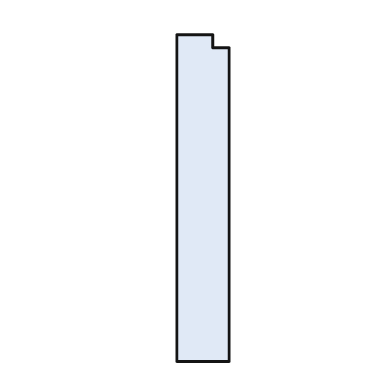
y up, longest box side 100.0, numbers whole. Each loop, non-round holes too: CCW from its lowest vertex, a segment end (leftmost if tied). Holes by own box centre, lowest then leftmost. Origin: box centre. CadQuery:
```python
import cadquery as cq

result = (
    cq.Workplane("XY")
    .moveTo(-8.0, -50.0)
    .lineTo(8.0, -50.0)
    .lineTo(8.0, 46.0)
    .lineTo(3.0, 46.0)
    .lineTo(3.0, 50.0)
    .lineTo(-8.0, 50.0)
    .close()
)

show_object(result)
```